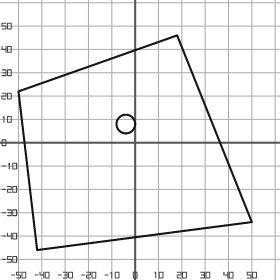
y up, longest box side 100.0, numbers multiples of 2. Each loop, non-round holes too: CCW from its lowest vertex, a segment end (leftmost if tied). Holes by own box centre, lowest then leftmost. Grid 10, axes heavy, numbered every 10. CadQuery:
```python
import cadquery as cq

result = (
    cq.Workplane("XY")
    .moveTo(-42.0, -46.0)
    .lineTo(50.0, -34.0)
    .lineTo(18.0, 46.0)
    .lineTo(-50.0, 22.0)
    .close()
    .moveTo(-4.0, 8.0)
    .circle(4.0)
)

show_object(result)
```